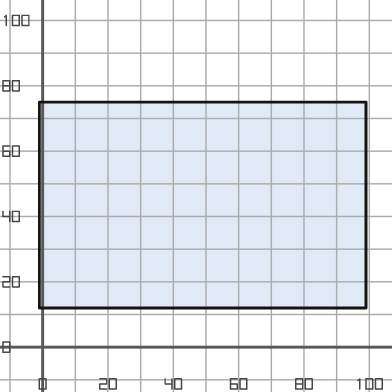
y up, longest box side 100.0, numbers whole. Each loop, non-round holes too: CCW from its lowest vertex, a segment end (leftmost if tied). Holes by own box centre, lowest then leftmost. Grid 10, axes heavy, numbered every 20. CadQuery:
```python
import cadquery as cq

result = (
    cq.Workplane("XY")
    .moveTo(-1.0, 12.0)
    .lineTo(99.0, 12.0)
    .lineTo(99.0, 75.0)
    .lineTo(-1.0, 75.0)
    .close()
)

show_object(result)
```